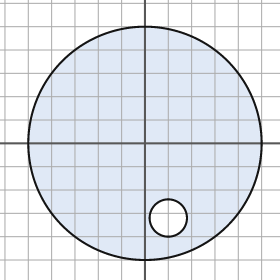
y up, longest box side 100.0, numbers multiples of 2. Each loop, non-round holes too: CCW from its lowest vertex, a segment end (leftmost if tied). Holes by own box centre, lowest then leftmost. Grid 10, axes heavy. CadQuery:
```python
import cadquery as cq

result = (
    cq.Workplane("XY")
    .moveTo(0.0, 0.0)
    .circle(50.0)
    .moveTo(10.0, -32.0)
    .circle(8.0)
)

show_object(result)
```